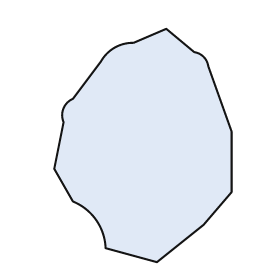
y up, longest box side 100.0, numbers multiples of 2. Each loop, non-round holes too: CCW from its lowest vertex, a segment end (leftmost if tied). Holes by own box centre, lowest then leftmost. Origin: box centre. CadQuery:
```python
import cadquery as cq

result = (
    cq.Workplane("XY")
    .moveTo(6.0, -50.0)
    .lineTo(26.0, -34.0)
    .lineTo(38.0, -20.0)
    .lineTo(38.0, 6.0)
    .lineTo(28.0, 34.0)
    .threePointArc((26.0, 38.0), (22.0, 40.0))
    .lineTo(10.0, 50.0)
    .lineTo(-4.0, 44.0)
    .threePointArc((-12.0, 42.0), (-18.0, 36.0))
    .lineTo(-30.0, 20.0)
    .threePointArc((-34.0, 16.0), (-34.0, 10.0))
    .lineTo(-38.0, -10.0)
    .lineTo(-30.0, -24.0)
    .threePointArc((-20.0, -32.0), (-16.0, -44.0))
    .close()
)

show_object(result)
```